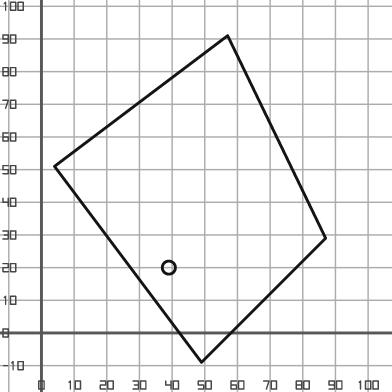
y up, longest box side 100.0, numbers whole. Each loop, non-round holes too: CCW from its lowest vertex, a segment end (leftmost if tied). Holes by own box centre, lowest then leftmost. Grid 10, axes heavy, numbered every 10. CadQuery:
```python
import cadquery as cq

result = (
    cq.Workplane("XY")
    .moveTo(49.0, -9.0)
    .lineTo(87.0, 29.0)
    .lineTo(57.0, 91.0)
    .lineTo(4.0, 51.0)
    .close()
    .moveTo(39.0, 20.0)
    .circle(2.0)
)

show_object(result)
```